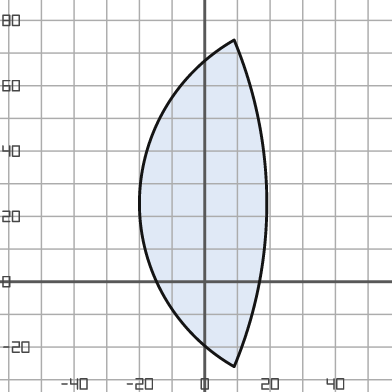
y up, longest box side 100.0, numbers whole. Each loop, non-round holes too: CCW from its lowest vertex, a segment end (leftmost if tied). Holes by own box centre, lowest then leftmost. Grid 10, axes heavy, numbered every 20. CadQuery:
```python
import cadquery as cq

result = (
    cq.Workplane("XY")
    .moveTo(9.0, -26.0)
    .threePointArc((19.0, 24.0), (9.0, 74.0))
    .threePointArc((-20.0, 24.0), (9.0, -26.0))
    .close()
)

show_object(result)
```